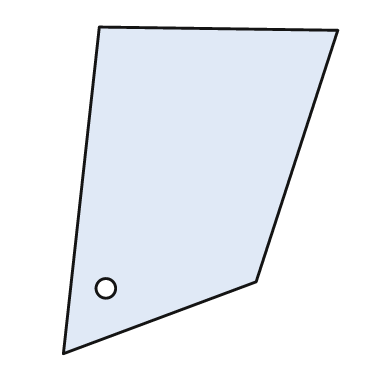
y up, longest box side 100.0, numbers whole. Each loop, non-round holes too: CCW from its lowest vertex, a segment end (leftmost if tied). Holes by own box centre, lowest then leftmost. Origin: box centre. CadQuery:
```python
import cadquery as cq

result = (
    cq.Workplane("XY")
    .moveTo(-42.0, -50.0)
    .lineTo(17.0, -28.0)
    .lineTo(42.0, 49.0)
    .lineTo(-31.0, 50.0)
    .close()
    .moveTo(-29.0, -30.0)
    .circle(3.0)
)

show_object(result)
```